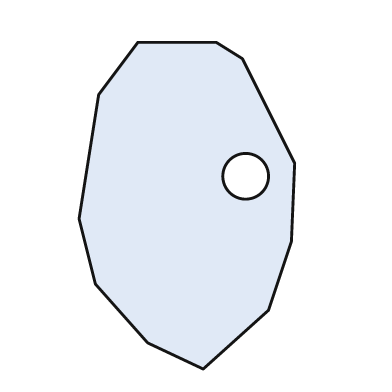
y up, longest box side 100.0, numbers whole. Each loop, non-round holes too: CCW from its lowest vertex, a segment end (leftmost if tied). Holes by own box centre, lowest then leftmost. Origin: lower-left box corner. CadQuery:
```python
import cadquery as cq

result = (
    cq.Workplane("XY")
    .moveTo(38.0, 0.0)
    .lineTo(58.0, 18.0)
    .lineTo(65.0, 39.0)
    .lineTo(66.0, 63.0)
    .lineTo(50.0, 95.0)
    .lineTo(42.0, 100.0)
    .lineTo(18.0, 100.0)
    .lineTo(6.0, 84.0)
    .lineTo(0.0, 46.0)
    .lineTo(5.0, 26.0)
    .lineTo(21.0, 8.0)
    .close()
    .moveTo(51.0, 59.0)
    .circle(7.0)
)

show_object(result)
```